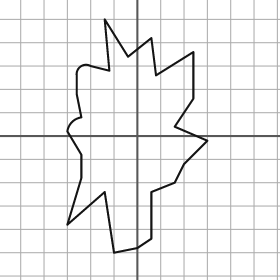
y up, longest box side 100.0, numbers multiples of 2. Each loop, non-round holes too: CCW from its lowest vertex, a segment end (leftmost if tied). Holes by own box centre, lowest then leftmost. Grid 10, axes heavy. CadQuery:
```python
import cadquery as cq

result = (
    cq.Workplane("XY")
    .moveTo(-10.0, -50.0)
    .lineTo(0.0, -48.0)
    .lineTo(6.0, -44.0)
    .lineTo(6.0, -24.0)
    .lineTo(16.0, -20.0)
    .lineTo(20.0, -12.0)
    .lineTo(30.0, -2.0)
    .lineTo(16.0, 4.0)
    .lineTo(24.0, 16.0)
    .lineTo(24.0, 36.0)
    .lineTo(8.0, 26.0)
    .lineTo(6.0, 42.0)
    .lineTo(-4.0, 34.0)
    .lineTo(-14.0, 50.0)
    .lineTo(-12.0, 28.0)
    .lineTo(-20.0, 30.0)
    .threePointArc((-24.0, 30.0), (-26.0, 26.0))
    .lineTo(-26.0, 18.0)
    .lineTo(-24.0, 8.0)
    .threePointArc((-28.0, 6.0), (-30.0, 2.0))
    .lineTo(-24.0, -8.0)
    .lineTo(-24.0, -18.0)
    .lineTo(-30.0, -38.0)
    .lineTo(-14.0, -24.0)
    .close()
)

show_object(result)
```